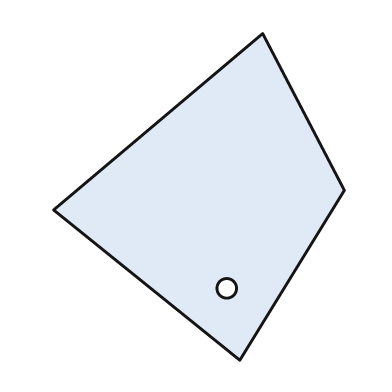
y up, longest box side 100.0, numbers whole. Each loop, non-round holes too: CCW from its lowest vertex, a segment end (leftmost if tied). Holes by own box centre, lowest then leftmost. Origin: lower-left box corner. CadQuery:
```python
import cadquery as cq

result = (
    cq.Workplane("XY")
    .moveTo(57.0, 0.0)
    .lineTo(89.0, 52.0)
    .lineTo(64.0, 100.0)
    .lineTo(0.0, 46.0)
    .close()
    .moveTo(53.0, 22.0)
    .circle(3.0)
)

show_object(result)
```